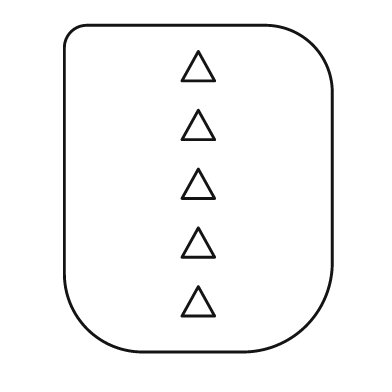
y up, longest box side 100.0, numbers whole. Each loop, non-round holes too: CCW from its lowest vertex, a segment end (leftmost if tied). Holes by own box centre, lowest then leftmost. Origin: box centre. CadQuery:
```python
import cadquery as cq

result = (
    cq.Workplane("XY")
    .moveTo(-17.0, -50.0)
    .lineTo(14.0, -50.0)
    .threePointArc((33.0, -42.0), (41.0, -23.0))
    .lineTo(41.0, 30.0)
    .threePointArc((35.0, 44.0), (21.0, 50.0))
    .lineTo(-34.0, 50.0)
    .threePointArc((-39.0, 48.0), (-41.0, 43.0))
    .lineTo(-41.0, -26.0)
    .threePointArc((-34.0, -43.0), (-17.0, -50.0))
    .close()
    .moveTo(-5.0, -39.0)
    .lineTo(5.0, -39.0)
    .lineTo(0.0, -30.0)
    .close()
    .moveTo(-5.0, -21.0)
    .lineTo(5.0, -21.0)
    .lineTo(0.0, -12.0)
    .close()
    .moveTo(-5.0, -3.0)
    .lineTo(5.0, -3.0)
    .lineTo(0.0, 6.0)
    .close()
    .moveTo(-5.0, 15.0)
    .lineTo(5.0, 15.0)
    .lineTo(0.0, 24.0)
    .close()
    .moveTo(-5.0, 33.0)
    .lineTo(5.0, 33.0)
    .lineTo(0.0, 42.0)
    .close()
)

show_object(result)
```